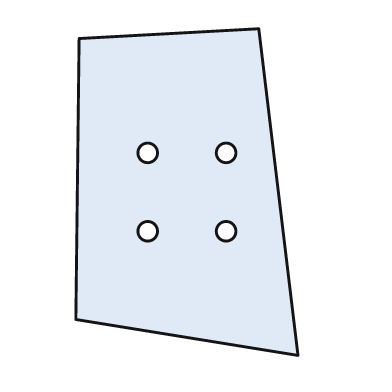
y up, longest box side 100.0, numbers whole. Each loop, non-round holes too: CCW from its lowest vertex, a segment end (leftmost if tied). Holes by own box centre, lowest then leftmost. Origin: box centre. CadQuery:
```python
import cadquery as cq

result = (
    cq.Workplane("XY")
    .moveTo(34.0, -50.0)
    .lineTo(22.0, 50.0)
    .lineTo(-33.0, 47.0)
    .lineTo(-34.0, -39.0)
    .close()
    .moveTo(-12.0, -12.0)
    .circle(3.0)
    .moveTo(12.0, -12.0)
    .circle(3.0)
    .moveTo(-12.0, 12.0)
    .circle(3.0)
    .moveTo(12.0, 12.0)
    .circle(3.0)
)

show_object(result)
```